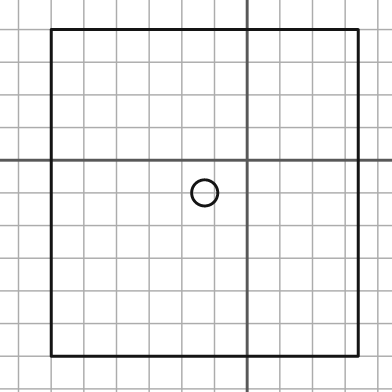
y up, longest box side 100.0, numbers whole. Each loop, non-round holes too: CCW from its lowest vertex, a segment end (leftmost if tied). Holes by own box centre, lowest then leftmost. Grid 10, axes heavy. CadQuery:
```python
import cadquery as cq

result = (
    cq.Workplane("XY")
    .moveTo(-60.0, -60.0)
    .lineTo(34.0, -60.0)
    .lineTo(34.0, 40.0)
    .lineTo(-60.0, 40.0)
    .close()
    .moveTo(-13.0, -10.0)
    .circle(4.0)
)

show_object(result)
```